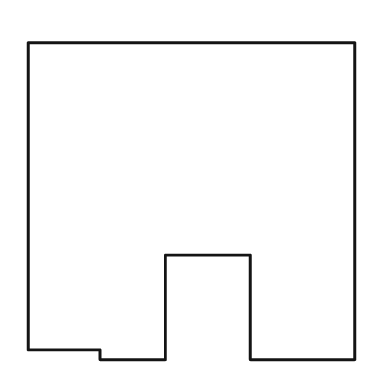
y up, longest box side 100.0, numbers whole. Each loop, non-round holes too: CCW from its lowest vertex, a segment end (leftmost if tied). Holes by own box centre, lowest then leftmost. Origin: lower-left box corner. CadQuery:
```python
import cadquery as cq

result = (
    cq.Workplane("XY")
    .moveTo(22.0, 0.0)
    .lineTo(42.0, 0.0)
    .lineTo(42.0, 32.0)
    .lineTo(68.0, 32.0)
    .lineTo(68.0, 0.0)
    .lineTo(100.0, 0.0)
    .lineTo(100.0, 97.0)
    .lineTo(0.0, 97.0)
    .lineTo(0.0, 3.0)
    .lineTo(22.0, 3.0)
    .close()
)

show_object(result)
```